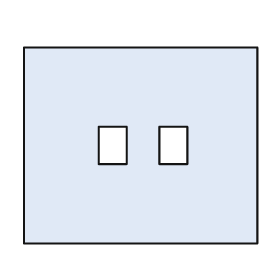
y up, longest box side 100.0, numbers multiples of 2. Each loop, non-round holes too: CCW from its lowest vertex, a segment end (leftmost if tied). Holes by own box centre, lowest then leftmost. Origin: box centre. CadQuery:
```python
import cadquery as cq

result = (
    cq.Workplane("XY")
    .moveTo(-50.0, -42.0)
    .lineTo(50.0, -42.0)
    .lineTo(50.0, 42.0)
    .lineTo(-50.0, 42.0)
    .close()
    .moveTo(-18.0, -8.0)
    .lineTo(-6.0, -8.0)
    .lineTo(-6.0, 8.0)
    .lineTo(-18.0, 8.0)
    .close()
    .moveTo(8.0, -8.0)
    .lineTo(20.0, -8.0)
    .lineTo(20.0, 8.0)
    .lineTo(8.0, 8.0)
    .close()
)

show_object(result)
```